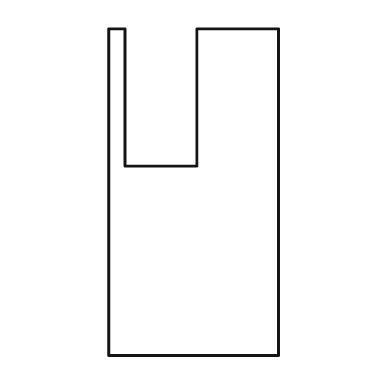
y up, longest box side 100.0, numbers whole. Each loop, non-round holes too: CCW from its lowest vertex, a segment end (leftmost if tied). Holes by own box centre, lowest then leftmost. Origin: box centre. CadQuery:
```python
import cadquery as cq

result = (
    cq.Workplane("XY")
    .moveTo(-26.0, -50.0)
    .lineTo(26.0, -50.0)
    .lineTo(26.0, 50.0)
    .lineTo(1.0, 50.0)
    .lineTo(1.0, 8.0)
    .lineTo(-21.0, 8.0)
    .lineTo(-21.0, 50.0)
    .lineTo(-26.0, 50.0)
    .close()
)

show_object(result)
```